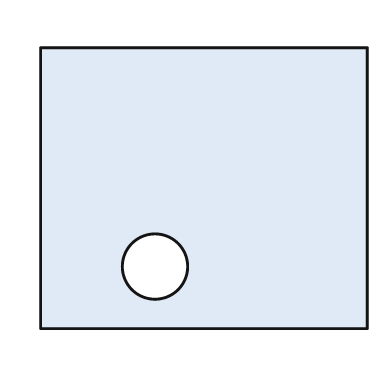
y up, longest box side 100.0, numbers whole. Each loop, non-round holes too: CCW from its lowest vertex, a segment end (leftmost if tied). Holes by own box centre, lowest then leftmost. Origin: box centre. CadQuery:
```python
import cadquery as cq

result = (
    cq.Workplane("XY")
    .moveTo(-50.0, -43.0)
    .lineTo(50.0, -43.0)
    .lineTo(50.0, 43.0)
    .lineTo(-50.0, 43.0)
    .close()
    .moveTo(-15.0, -24.0)
    .circle(10.0)
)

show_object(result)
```